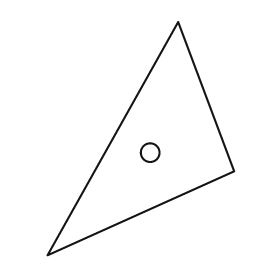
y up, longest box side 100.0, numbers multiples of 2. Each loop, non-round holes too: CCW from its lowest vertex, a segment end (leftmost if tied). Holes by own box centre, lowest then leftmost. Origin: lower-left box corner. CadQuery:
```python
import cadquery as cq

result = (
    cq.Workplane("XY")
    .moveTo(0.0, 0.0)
    .lineTo(80.0, 36.0)
    .lineTo(56.0, 100.0)
    .close()
    .moveTo(44.0, 44.0)
    .circle(4.0)
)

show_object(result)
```